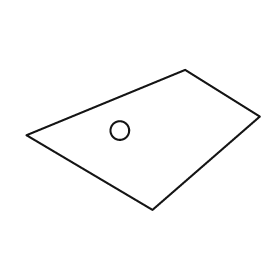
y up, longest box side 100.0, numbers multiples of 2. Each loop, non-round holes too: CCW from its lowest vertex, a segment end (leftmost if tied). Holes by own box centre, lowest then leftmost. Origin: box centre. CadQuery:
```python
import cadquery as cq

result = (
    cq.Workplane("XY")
    .moveTo(4.0, -30.0)
    .lineTo(50.0, 10.0)
    .lineTo(18.0, 30.0)
    .lineTo(-50.0, 2.0)
    .close()
    .moveTo(-10.0, 4.0)
    .circle(4.0)
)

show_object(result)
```